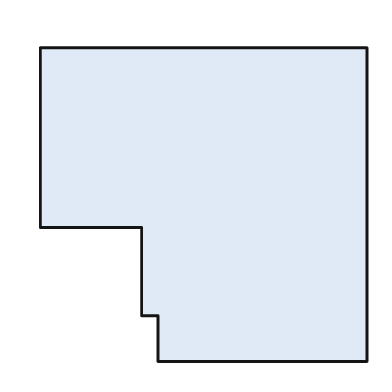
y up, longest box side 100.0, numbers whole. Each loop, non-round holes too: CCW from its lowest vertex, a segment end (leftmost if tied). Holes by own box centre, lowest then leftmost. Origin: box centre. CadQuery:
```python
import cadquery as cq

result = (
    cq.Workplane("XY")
    .moveTo(-14.0, -48.0)
    .lineTo(50.0, -48.0)
    .lineTo(50.0, 48.0)
    .lineTo(-50.0, 48.0)
    .lineTo(-50.0, -7.0)
    .lineTo(-19.0, -7.0)
    .lineTo(-19.0, -34.0)
    .lineTo(-14.0, -34.0)
    .close()
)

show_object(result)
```